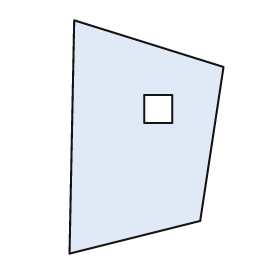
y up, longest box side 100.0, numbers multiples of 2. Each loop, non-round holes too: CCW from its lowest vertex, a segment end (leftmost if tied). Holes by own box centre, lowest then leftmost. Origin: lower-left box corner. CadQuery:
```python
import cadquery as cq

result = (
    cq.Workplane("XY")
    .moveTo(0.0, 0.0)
    .lineTo(56.0, 14.0)
    .lineTo(66.0, 80.0)
    .lineTo(2.0, 100.0)
    .close()
    .moveTo(32.0, 56.0)
    .lineTo(44.0, 56.0)
    .lineTo(44.0, 68.0)
    .lineTo(32.0, 68.0)
    .close()
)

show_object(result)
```